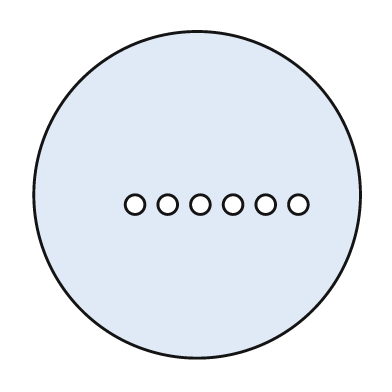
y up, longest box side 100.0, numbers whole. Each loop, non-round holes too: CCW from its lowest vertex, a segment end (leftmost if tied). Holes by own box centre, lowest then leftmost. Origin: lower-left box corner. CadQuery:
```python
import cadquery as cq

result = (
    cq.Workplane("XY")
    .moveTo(50.0, 50.0)
    .circle(50.0)
    .moveTo(31.0, 47.0)
    .circle(3.0)
    .moveTo(41.0, 47.0)
    .circle(3.0)
    .moveTo(51.0, 47.0)
    .circle(3.0)
    .moveTo(61.0, 47.0)
    .circle(3.0)
    .moveTo(71.0, 47.0)
    .circle(3.0)
    .moveTo(81.0, 47.0)
    .circle(3.0)
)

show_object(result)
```